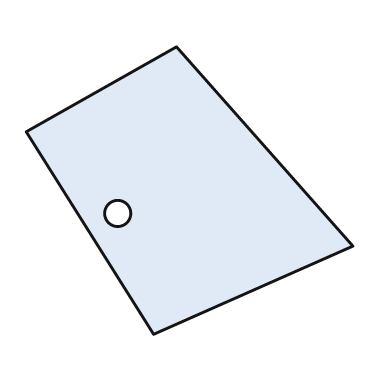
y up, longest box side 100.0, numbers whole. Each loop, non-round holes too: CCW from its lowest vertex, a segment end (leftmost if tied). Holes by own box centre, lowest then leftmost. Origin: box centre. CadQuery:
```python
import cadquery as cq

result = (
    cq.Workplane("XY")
    .moveTo(-11.0, -44.0)
    .lineTo(50.0, -17.0)
    .lineTo(-4.0, 44.0)
    .lineTo(-50.0, 18.0)
    .close()
    .moveTo(-22.0, -7.0)
    .circle(4.0)
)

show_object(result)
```